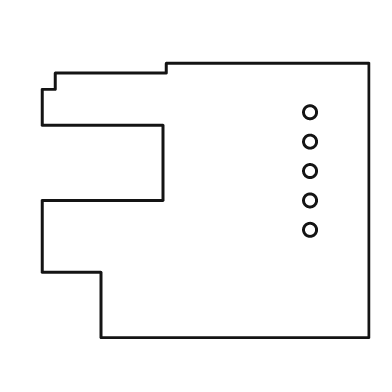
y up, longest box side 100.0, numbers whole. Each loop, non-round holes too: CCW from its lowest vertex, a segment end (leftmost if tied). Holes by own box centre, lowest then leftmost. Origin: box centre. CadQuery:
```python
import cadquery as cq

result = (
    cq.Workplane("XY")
    .moveTo(-32.0, -42.0)
    .lineTo(50.0, -42.0)
    .lineTo(50.0, 42.0)
    .lineTo(-12.0, 42.0)
    .lineTo(-12.0, 39.0)
    .lineTo(-46.0, 39.0)
    .lineTo(-46.0, 34.0)
    .lineTo(-50.0, 34.0)
    .lineTo(-50.0, 23.0)
    .lineTo(-13.0, 23.0)
    .lineTo(-13.0, 0.0)
    .lineTo(-50.0, 0.0)
    .lineTo(-50.0, -22.0)
    .lineTo(-32.0, -22.0)
    .close()
    .moveTo(32.0, -9.0)
    .circle(2.0)
    .moveTo(32.0, 0.0)
    .circle(2.0)
    .moveTo(32.0, 9.0)
    .circle(2.0)
    .moveTo(32.0, 18.0)
    .circle(2.0)
    .moveTo(32.0, 27.0)
    .circle(2.0)
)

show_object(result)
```